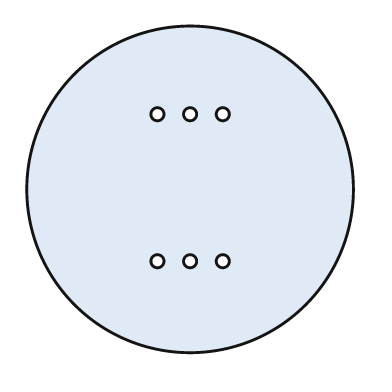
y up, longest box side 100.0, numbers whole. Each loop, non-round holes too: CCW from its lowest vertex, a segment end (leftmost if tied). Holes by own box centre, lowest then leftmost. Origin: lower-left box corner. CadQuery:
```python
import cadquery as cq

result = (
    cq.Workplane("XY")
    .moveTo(50.0, 50.0)
    .circle(50.0)
    .moveTo(40.0, 28.0)
    .circle(2.0)
    .moveTo(50.0, 28.0)
    .circle(2.0)
    .moveTo(60.0, 28.0)
    .circle(2.0)
    .moveTo(40.0, 73.0)
    .circle(2.0)
    .moveTo(50.0, 73.0)
    .circle(2.0)
    .moveTo(60.0, 73.0)
    .circle(2.0)
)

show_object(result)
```